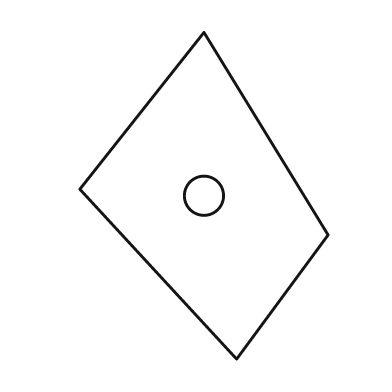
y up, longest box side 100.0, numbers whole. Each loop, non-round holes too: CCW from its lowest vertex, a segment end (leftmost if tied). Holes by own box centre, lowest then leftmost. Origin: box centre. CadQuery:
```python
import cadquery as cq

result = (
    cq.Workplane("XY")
    .moveTo(10.0, -50.0)
    .lineTo(38.0, -12.0)
    .lineTo(0.0, 50.0)
    .lineTo(-38.0, 2.0)
    .close()
    .moveTo(0.0, 0.0)
    .circle(6.0)
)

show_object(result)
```